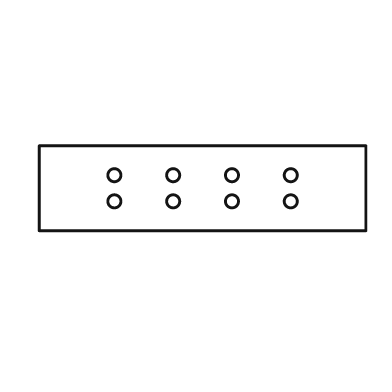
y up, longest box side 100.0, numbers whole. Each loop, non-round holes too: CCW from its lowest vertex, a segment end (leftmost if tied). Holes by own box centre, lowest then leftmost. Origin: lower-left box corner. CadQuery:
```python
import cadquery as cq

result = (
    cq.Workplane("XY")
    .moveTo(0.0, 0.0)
    .lineTo(100.0, 0.0)
    .lineTo(100.0, 26.0)
    .lineTo(0.0, 26.0)
    .close()
    .moveTo(23.0, 9.0)
    .circle(2.0)
    .moveTo(41.0, 9.0)
    .circle(2.0)
    .moveTo(59.0, 9.0)
    .circle(2.0)
    .moveTo(77.0, 9.0)
    .circle(2.0)
    .moveTo(23.0, 17.0)
    .circle(2.0)
    .moveTo(41.0, 17.0)
    .circle(2.0)
    .moveTo(59.0, 17.0)
    .circle(2.0)
    .moveTo(77.0, 17.0)
    .circle(2.0)
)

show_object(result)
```